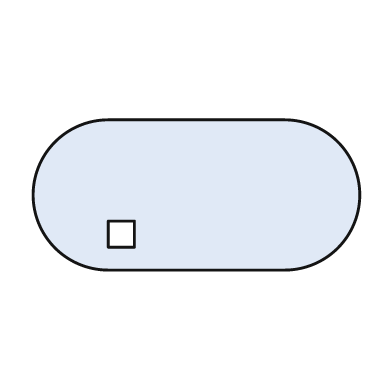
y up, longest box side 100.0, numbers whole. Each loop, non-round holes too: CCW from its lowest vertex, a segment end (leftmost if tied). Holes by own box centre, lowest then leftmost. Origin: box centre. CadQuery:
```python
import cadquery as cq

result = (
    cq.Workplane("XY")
    .moveTo(-27.0, -23.0)
    .lineTo(27.0, -23.0)
    .threePointArc((50.0, 0.0), (27.0, 23.0))
    .lineTo(-27.0, 23.0)
    .threePointArc((-50.0, 0.0), (-27.0, -23.0))
    .close()
    .moveTo(-27.0, -16.0)
    .lineTo(-19.0, -16.0)
    .lineTo(-19.0, -8.0)
    .lineTo(-27.0, -8.0)
    .close()
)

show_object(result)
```